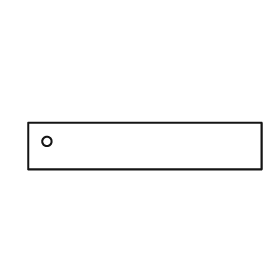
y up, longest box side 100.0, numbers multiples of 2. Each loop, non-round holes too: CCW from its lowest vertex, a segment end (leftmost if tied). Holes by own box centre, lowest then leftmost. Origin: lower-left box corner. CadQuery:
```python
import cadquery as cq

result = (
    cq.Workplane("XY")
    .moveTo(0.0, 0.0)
    .lineTo(100.0, 0.0)
    .lineTo(100.0, 20.0)
    .lineTo(0.0, 20.0)
    .close()
    .moveTo(8.0, 12.0)
    .circle(2.0)
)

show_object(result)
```